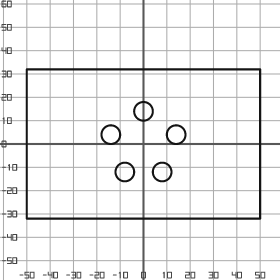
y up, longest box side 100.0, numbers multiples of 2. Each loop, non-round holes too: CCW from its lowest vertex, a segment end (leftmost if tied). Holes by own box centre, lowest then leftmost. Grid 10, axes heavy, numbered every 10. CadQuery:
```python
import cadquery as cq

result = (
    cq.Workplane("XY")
    .moveTo(-50.0, -32.0)
    .lineTo(50.0, -32.0)
    .lineTo(50.0, 32.0)
    .lineTo(-50.0, 32.0)
    .close()
    .moveTo(-8.0, -12.0)
    .circle(4.0)
    .moveTo(8.0, -12.0)
    .circle(4.0)
    .moveTo(-14.0, 4.0)
    .circle(4.0)
    .moveTo(14.0, 4.0)
    .circle(4.0)
    .moveTo(0.0, 14.0)
    .circle(4.0)
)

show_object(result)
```